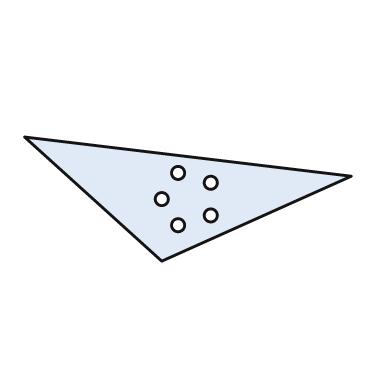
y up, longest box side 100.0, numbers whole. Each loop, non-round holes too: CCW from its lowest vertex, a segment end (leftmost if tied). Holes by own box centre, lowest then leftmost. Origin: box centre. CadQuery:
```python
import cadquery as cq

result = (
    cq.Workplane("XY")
    .moveTo(-8.0, -19.0)
    .lineTo(50.0, 7.0)
    .lineTo(-50.0, 19.0)
    .close()
    .moveTo(-3.0, -8.0)
    .circle(2.0)
    .moveTo(7.0, -5.0)
    .circle(2.0)
    .moveTo(-8.0, 0.0)
    .circle(2.0)
    .moveTo(7.0, 5.0)
    .circle(2.0)
    .moveTo(-3.0, 8.0)
    .circle(2.0)
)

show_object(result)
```